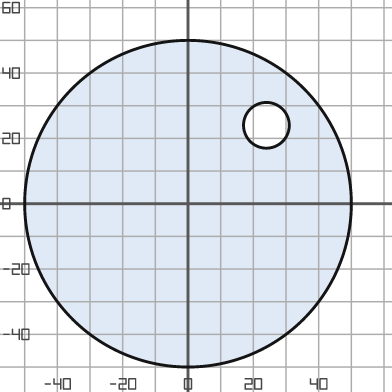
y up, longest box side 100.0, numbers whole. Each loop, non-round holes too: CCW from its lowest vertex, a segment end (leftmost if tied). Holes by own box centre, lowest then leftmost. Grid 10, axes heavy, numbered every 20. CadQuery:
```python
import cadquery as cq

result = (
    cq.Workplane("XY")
    .moveTo(0.0, 0.0)
    .circle(50.0)
    .moveTo(24.0, 24.0)
    .circle(7.0)
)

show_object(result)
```